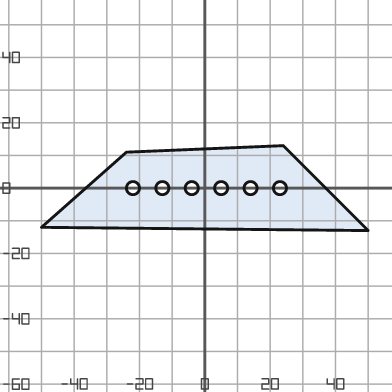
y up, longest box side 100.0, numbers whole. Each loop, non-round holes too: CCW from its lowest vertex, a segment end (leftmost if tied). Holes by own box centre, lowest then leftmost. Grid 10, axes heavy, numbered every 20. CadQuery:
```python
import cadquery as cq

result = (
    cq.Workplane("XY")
    .moveTo(50.0, -13.0)
    .lineTo(24.0, 13.0)
    .lineTo(-24.0, 11.0)
    .lineTo(-50.0, -12.0)
    .close()
    .moveTo(-22.0, 0.0)
    .circle(2.0)
    .moveTo(-13.0, 0.0)
    .circle(2.0)
    .moveTo(-4.0, 0.0)
    .circle(2.0)
    .moveTo(5.0, 0.0)
    .circle(2.0)
    .moveTo(14.0, 0.0)
    .circle(2.0)
    .moveTo(23.0, 0.0)
    .circle(2.0)
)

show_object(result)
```